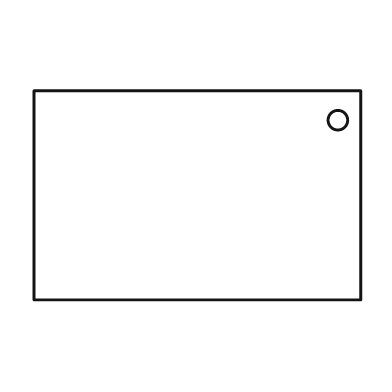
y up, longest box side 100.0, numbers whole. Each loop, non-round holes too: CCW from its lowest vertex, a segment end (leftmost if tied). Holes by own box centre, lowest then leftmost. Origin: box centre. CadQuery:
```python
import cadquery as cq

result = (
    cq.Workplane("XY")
    .moveTo(-50.0, -32.0)
    .lineTo(50.0, -32.0)
    .lineTo(50.0, 32.0)
    .lineTo(-50.0, 32.0)
    .close()
    .moveTo(43.0, 23.0)
    .circle(3.0)
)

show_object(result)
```